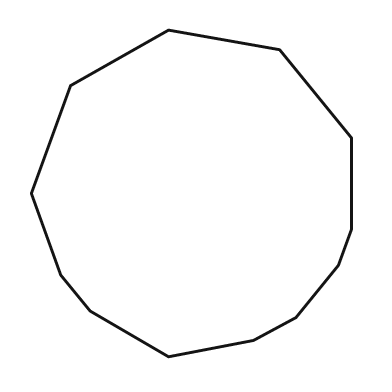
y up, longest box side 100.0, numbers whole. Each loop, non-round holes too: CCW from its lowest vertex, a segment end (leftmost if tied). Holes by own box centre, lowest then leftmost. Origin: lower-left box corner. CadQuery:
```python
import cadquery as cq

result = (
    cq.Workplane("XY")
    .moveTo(42.0, 0.0)
    .lineTo(68.0, 5.0)
    .lineTo(81.0, 12.0)
    .lineTo(94.0, 28.0)
    .lineTo(98.0, 39.0)
    .lineTo(98.0, 67.0)
    .lineTo(76.0, 94.0)
    .lineTo(42.0, 100.0)
    .lineTo(12.0, 83.0)
    .lineTo(0.0, 50.0)
    .lineTo(9.0, 25.0)
    .lineTo(18.0, 14.0)
    .close()
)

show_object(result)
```